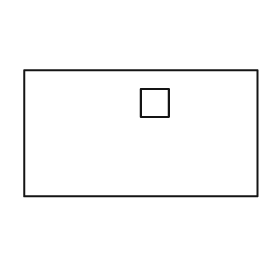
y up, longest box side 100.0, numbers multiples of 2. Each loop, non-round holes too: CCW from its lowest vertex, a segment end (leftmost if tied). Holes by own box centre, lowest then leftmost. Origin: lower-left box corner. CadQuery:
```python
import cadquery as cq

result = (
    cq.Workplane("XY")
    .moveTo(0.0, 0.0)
    .lineTo(100.0, 0.0)
    .lineTo(100.0, 54.0)
    .lineTo(0.0, 54.0)
    .close()
    .moveTo(50.0, 34.0)
    .lineTo(62.0, 34.0)
    .lineTo(62.0, 46.0)
    .lineTo(50.0, 46.0)
    .close()
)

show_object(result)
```